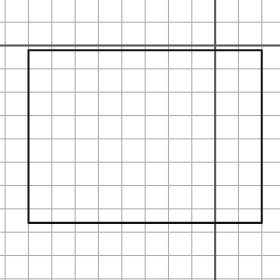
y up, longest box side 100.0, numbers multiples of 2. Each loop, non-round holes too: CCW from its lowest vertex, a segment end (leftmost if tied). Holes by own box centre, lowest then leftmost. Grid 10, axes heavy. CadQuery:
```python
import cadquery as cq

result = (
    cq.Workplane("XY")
    .moveTo(-80.0, -76.0)
    .lineTo(20.0, -76.0)
    .lineTo(20.0, -2.0)
    .lineTo(-80.0, -2.0)
    .close()
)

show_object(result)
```